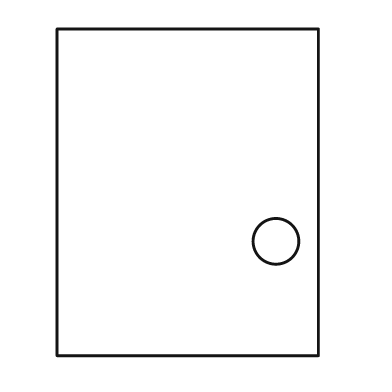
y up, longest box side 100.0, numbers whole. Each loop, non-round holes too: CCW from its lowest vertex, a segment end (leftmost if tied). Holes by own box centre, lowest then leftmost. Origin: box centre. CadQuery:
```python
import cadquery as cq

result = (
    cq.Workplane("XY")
    .moveTo(-40.0, -50.0)
    .lineTo(40.0, -50.0)
    .lineTo(40.0, 50.0)
    .lineTo(-40.0, 50.0)
    .close()
    .moveTo(27.0, -15.0)
    .circle(7.0)
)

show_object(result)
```